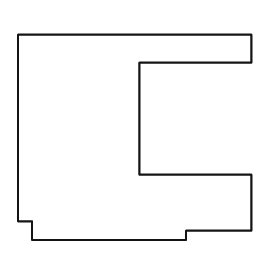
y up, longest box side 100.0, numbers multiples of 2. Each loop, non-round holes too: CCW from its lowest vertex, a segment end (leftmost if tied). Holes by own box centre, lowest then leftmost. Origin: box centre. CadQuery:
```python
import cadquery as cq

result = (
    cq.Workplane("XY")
    .moveTo(-44.0, -44.0)
    .lineTo(22.0, -44.0)
    .lineTo(22.0, -40.0)
    .lineTo(50.0, -40.0)
    .lineTo(50.0, -16.0)
    .lineTo(2.0, -16.0)
    .lineTo(2.0, 32.0)
    .lineTo(50.0, 32.0)
    .lineTo(50.0, 44.0)
    .lineTo(-50.0, 44.0)
    .lineTo(-50.0, -36.0)
    .lineTo(-44.0, -36.0)
    .close()
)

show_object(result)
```